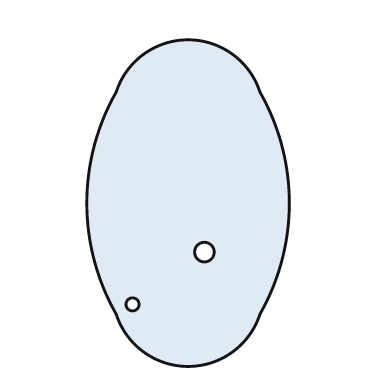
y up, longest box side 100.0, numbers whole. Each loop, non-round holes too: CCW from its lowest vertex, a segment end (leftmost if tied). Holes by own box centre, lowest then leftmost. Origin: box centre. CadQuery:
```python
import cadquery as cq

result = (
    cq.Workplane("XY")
    .moveTo(-22.0, -34.0)
    .threePointArc((0.0, -50.0), (22.0, -34.0))
    .threePointArc((31.0, 0.0), (22.0, 34.0))
    .threePointArc((0.0, 50.0), (-22.0, 34.0))
    .threePointArc((-31.0, 0.0), (-22.0, -34.0))
    .close()
    .moveTo(-17.0, -31.0)
    .circle(2.0)
    .moveTo(5.0, -15.0)
    .circle(3.0)
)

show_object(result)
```